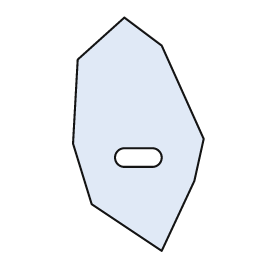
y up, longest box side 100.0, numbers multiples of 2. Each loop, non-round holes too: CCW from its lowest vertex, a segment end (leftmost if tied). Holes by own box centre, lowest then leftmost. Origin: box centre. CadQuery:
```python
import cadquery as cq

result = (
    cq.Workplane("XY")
    .moveTo(10.0, -50.0)
    .lineTo(24.0, -20.0)
    .lineTo(28.0, -2.0)
    .lineTo(10.0, 38.0)
    .lineTo(-6.0, 50.0)
    .lineTo(-26.0, 32.0)
    .lineTo(-28.0, -4.0)
    .lineTo(-20.0, -30.0)
    .close()
    .moveTo(-6.0, -14.0)
    .lineTo(6.0, -14.0)
    .threePointArc((10.0, -10.0), (6.0, -6.0))
    .lineTo(-6.0, -6.0)
    .threePointArc((-10.0, -10.0), (-6.0, -14.0))
    .close()
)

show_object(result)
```